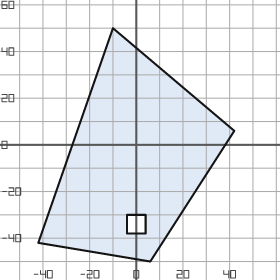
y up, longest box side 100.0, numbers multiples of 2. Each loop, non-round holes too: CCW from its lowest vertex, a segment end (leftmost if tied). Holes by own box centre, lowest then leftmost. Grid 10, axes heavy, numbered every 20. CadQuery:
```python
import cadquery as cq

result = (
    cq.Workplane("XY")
    .moveTo(6.0, -50.0)
    .lineTo(42.0, 6.0)
    .lineTo(-10.0, 50.0)
    .lineTo(-42.0, -42.0)
    .close()
    .moveTo(-4.0, -38.0)
    .lineTo(4.0, -38.0)
    .lineTo(4.0, -30.0)
    .lineTo(-4.0, -30.0)
    .close()
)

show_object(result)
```